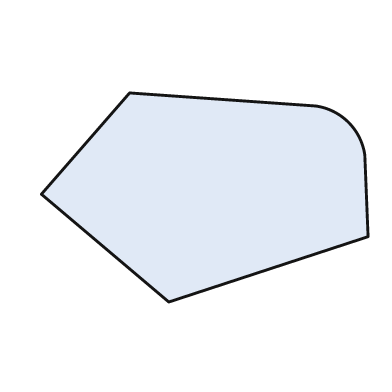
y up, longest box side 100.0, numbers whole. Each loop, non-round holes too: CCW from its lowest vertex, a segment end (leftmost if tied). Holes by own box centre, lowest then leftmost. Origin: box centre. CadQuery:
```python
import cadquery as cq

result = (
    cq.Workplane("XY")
    .moveTo(-11.0, -32.0)
    .lineTo(50.0, -12.0)
    .lineTo(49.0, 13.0)
    .threePointArc((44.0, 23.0), (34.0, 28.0))
    .lineTo(-23.0, 32.0)
    .lineTo(-50.0, 1.0)
    .close()
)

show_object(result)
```